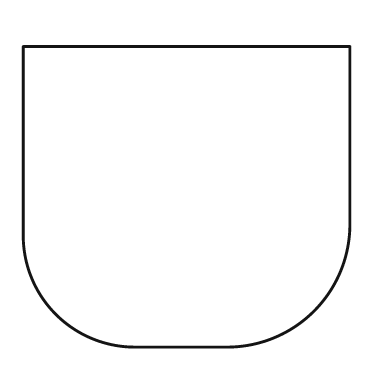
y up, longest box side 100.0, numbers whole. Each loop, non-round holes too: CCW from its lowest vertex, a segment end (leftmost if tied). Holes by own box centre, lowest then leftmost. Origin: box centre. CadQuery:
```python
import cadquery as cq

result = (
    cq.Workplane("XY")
    .moveTo(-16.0, -46.0)
    .lineTo(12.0, -46.0)
    .threePointArc((39.0, -35.0), (50.0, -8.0))
    .lineTo(50.0, 46.0)
    .lineTo(-50.0, 46.0)
    .lineTo(-50.0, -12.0)
    .threePointArc((-40.0, -36.0), (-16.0, -46.0))
    .close()
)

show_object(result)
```